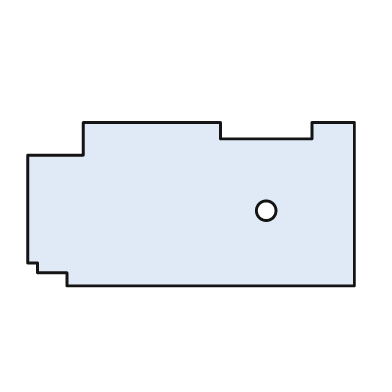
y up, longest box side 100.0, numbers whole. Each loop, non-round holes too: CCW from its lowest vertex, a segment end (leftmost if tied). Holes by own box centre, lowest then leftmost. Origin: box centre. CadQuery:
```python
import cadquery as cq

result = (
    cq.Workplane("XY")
    .moveTo(-38.0, -25.0)
    .lineTo(50.0, -25.0)
    .lineTo(50.0, 25.0)
    .lineTo(37.0, 25.0)
    .lineTo(37.0, 20.0)
    .lineTo(9.0, 20.0)
    .lineTo(9.0, 25.0)
    .lineTo(-33.0, 25.0)
    .lineTo(-33.0, 15.0)
    .lineTo(-50.0, 15.0)
    .lineTo(-50.0, -18.0)
    .lineTo(-47.0, -18.0)
    .lineTo(-47.0, -21.0)
    .lineTo(-38.0, -21.0)
    .close()
    .moveTo(23.0, -2.0)
    .circle(3.0)
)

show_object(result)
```